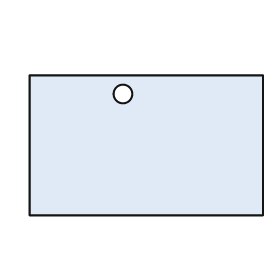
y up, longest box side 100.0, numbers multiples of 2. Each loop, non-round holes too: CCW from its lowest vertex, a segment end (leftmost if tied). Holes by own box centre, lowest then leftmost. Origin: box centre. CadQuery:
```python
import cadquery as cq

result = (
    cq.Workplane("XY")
    .moveTo(-50.0, -30.0)
    .lineTo(50.0, -30.0)
    .lineTo(50.0, 30.0)
    .lineTo(-50.0, 30.0)
    .close()
    .moveTo(-10.0, 22.0)
    .circle(4.0)
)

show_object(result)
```